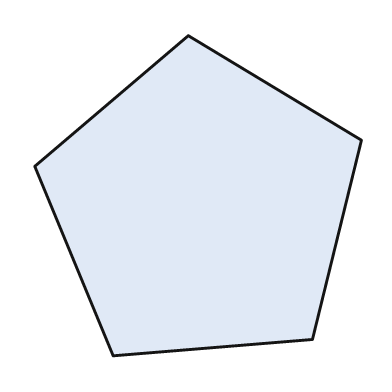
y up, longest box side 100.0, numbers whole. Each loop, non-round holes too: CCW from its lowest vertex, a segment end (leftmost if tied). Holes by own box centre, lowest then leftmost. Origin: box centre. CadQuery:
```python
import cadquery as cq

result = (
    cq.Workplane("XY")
    .moveTo(-26.0, -49.0)
    .lineTo(35.0, -44.0)
    .lineTo(50.0, 17.0)
    .lineTo(-3.0, 49.0)
    .lineTo(-50.0, 9.0)
    .close()
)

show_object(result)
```